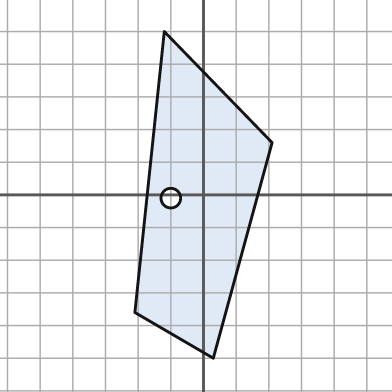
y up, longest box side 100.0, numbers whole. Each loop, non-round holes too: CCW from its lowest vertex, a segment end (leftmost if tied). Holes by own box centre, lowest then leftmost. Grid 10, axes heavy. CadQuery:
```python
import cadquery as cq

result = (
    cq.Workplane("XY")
    .moveTo(3.0, -50.0)
    .lineTo(21.0, 16.0)
    .lineTo(-12.0, 50.0)
    .lineTo(-21.0, -36.0)
    .close()
    .moveTo(-10.0, -1.0)
    .circle(3.0)
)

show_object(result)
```